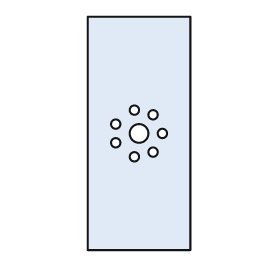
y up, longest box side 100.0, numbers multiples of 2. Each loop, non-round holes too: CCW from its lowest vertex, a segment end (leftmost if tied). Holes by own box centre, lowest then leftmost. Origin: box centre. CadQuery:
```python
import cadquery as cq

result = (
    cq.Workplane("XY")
    .moveTo(-22.0, -50.0)
    .lineTo(22.0, -50.0)
    .lineTo(22.0, 50.0)
    .lineTo(-22.0, 50.0)
    .close()
    .moveTo(-2.0, -10.0)
    .circle(2.0)
    .moveTo(6.0, -8.0)
    .circle(2.0)
    .moveTo(-10.0, -4.0)
    .circle(2.0)
    .moveTo(0.0, 0.0)
    .circle(4.0)
    .moveTo(10.0, 0.0)
    .circle(2.0)
    .moveTo(-10.0, 4.0)
    .circle(2.0)
    .moveTo(6.0, 8.0)
    .circle(2.0)
    .moveTo(-2.0, 10.0)
    .circle(2.0)
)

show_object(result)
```